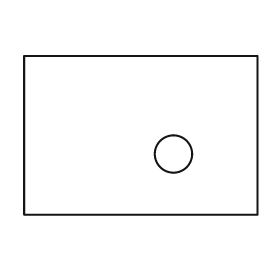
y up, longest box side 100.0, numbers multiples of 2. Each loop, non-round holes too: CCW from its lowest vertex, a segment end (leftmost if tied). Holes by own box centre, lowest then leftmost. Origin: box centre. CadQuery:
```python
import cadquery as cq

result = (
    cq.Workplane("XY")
    .moveTo(-50.0, -34.0)
    .lineTo(50.0, -34.0)
    .lineTo(50.0, 34.0)
    .lineTo(-50.0, 34.0)
    .close()
    .moveTo(14.0, -8.0)
    .circle(8.0)
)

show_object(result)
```